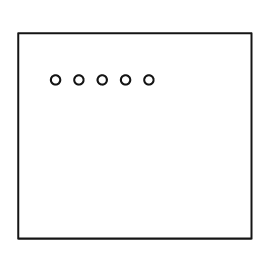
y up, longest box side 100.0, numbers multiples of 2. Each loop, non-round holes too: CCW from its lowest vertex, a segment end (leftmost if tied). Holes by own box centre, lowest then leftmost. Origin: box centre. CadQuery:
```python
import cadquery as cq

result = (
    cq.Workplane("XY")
    .moveTo(-50.0, -44.0)
    .lineTo(50.0, -44.0)
    .lineTo(50.0, 44.0)
    .lineTo(-50.0, 44.0)
    .close()
    .moveTo(-34.0, 24.0)
    .circle(2.0)
    .moveTo(-24.0, 24.0)
    .circle(2.0)
    .moveTo(-14.0, 24.0)
    .circle(2.0)
    .moveTo(-4.0, 24.0)
    .circle(2.0)
    .moveTo(6.0, 24.0)
    .circle(2.0)
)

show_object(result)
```